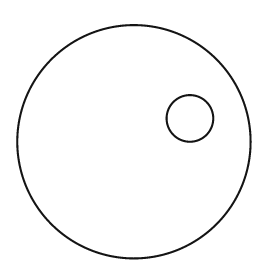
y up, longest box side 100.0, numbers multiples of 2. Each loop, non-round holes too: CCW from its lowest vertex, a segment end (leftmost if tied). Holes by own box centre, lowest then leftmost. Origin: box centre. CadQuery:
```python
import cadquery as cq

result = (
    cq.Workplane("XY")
    .moveTo(0.0, 0.0)
    .circle(50.0)
    .moveTo(24.0, 10.0)
    .circle(10.0)
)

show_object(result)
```